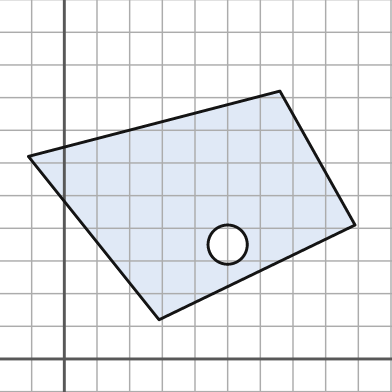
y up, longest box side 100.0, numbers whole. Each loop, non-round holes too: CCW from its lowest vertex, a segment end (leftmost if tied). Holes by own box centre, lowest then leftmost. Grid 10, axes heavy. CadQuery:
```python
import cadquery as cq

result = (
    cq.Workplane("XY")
    .moveTo(29.0, 12.0)
    .lineTo(89.0, 41.0)
    .lineTo(66.0, 82.0)
    .lineTo(-11.0, 62.0)
    .close()
    .moveTo(50.0, 35.0)
    .circle(6.0)
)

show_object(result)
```